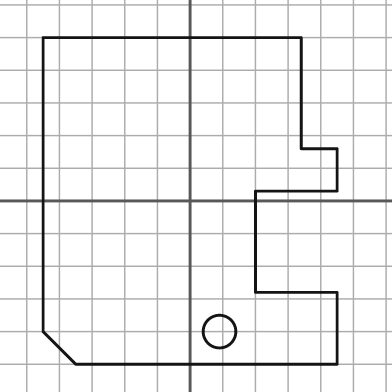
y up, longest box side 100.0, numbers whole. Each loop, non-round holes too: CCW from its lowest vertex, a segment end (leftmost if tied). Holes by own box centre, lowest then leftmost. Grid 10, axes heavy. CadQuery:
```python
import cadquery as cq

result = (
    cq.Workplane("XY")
    .moveTo(-35.0, -50.0)
    .lineTo(45.0, -50.0)
    .lineTo(45.0, -28.0)
    .lineTo(20.0, -28.0)
    .lineTo(20.0, 3.0)
    .lineTo(45.0, 3.0)
    .lineTo(45.0, 16.0)
    .lineTo(34.0, 16.0)
    .lineTo(34.0, 50.0)
    .lineTo(-45.0, 50.0)
    .lineTo(-45.0, -40.0)
    .close()
    .moveTo(9.0, -40.0)
    .circle(5.0)
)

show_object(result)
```